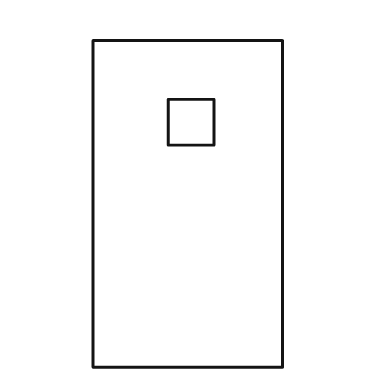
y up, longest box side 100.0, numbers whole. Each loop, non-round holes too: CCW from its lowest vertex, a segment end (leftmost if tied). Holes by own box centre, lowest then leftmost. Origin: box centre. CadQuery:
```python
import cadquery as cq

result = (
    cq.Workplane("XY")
    .moveTo(-29.0, -50.0)
    .lineTo(29.0, -50.0)
    .lineTo(29.0, 50.0)
    .lineTo(-29.0, 50.0)
    .close()
    .moveTo(-6.0, 18.0)
    .lineTo(8.0, 18.0)
    .lineTo(8.0, 32.0)
    .lineTo(-6.0, 32.0)
    .close()
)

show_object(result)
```